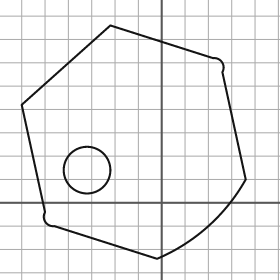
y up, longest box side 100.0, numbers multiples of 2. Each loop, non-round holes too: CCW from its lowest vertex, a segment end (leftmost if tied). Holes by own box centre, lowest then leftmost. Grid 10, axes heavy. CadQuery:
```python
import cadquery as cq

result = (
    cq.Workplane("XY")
    .moveTo(-2.0, -24.0)
    .threePointArc((20.0, -10.0), (36.0, 10.0))
    .lineTo(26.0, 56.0)
    .threePointArc((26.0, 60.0), (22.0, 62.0))
    .lineTo(-22.0, 76.0)
    .lineTo(-60.0, 42.0)
    .lineTo(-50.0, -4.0)
    .threePointArc((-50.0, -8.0), (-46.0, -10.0))
    .close()
    .moveTo(-32.0, 14.0)
    .circle(10.0)
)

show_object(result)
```